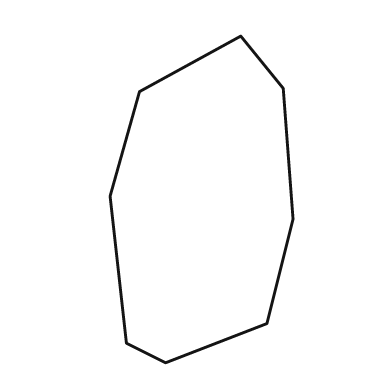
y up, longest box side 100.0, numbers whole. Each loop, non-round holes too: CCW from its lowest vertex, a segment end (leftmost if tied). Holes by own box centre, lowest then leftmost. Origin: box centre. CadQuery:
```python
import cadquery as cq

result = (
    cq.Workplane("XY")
    .moveTo(-11.0, -50.0)
    .lineTo(20.0, -38.0)
    .lineTo(28.0, -6.0)
    .lineTo(25.0, 34.0)
    .lineTo(12.0, 50.0)
    .lineTo(-19.0, 33.0)
    .lineTo(-28.0, 1.0)
    .lineTo(-23.0, -44.0)
    .close()
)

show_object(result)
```